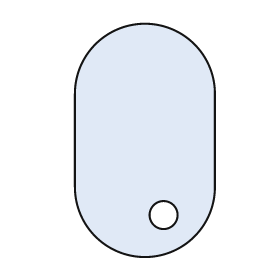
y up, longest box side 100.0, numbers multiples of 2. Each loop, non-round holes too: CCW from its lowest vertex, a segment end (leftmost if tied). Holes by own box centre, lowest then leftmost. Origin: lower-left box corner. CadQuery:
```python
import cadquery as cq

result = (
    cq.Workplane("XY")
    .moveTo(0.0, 30.0)
    .threePointArc((30.0, 0.0), (60.0, 30.0))
    .lineTo(60.0, 70.0)
    .threePointArc((30.0, 100.0), (0.0, 70.0))
    .close()
    .moveTo(38.0, 18.0)
    .circle(6.0)
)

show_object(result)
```